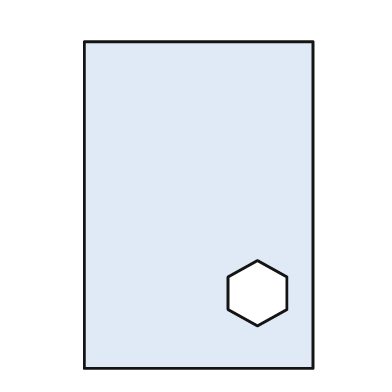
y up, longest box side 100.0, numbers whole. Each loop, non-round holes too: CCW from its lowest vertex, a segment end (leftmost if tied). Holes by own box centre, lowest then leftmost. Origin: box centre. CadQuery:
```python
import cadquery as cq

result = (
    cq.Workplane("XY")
    .moveTo(-35.0, -50.0)
    .lineTo(35.0, -50.0)
    .lineTo(35.0, 50.0)
    .lineTo(-35.0, 50.0)
    .close()
    .moveTo(18.0, -37.0)
    .lineTo(27.0, -32.0)
    .lineTo(27.0, -22.0)
    .lineTo(18.0, -17.0)
    .lineTo(9.0, -22.0)
    .lineTo(9.0, -32.0)
    .close()
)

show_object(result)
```